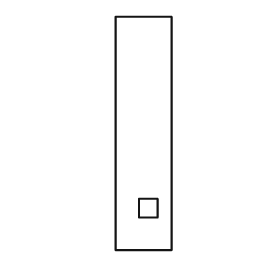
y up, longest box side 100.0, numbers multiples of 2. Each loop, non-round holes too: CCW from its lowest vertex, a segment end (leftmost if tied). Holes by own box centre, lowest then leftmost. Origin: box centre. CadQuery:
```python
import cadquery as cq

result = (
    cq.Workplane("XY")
    .moveTo(-12.0, -50.0)
    .lineTo(12.0, -50.0)
    .lineTo(12.0, 50.0)
    .lineTo(-12.0, 50.0)
    .close()
    .moveTo(-2.0, -36.0)
    .lineTo(6.0, -36.0)
    .lineTo(6.0, -28.0)
    .lineTo(-2.0, -28.0)
    .close()
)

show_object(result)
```